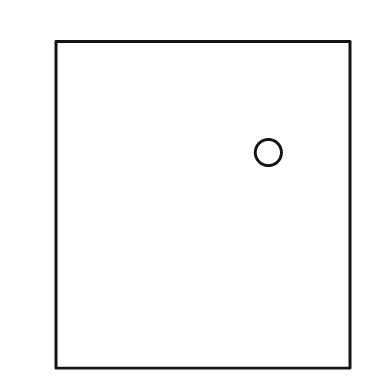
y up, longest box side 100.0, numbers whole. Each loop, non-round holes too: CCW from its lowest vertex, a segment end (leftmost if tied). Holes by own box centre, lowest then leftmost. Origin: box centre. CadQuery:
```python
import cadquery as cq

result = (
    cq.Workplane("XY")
    .moveTo(-45.0, -50.0)
    .lineTo(45.0, -50.0)
    .lineTo(45.0, 50.0)
    .lineTo(-45.0, 50.0)
    .close()
    .moveTo(20.0, 16.0)
    .circle(4.0)
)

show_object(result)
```